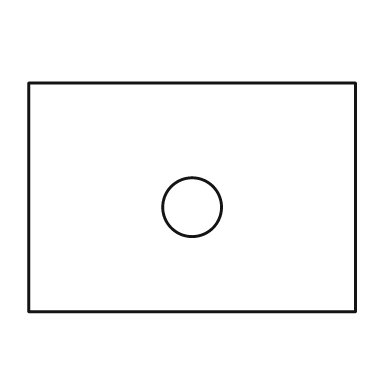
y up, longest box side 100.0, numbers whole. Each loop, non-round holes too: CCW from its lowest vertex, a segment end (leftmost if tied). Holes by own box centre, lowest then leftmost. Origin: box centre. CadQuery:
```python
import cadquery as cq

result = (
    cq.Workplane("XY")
    .moveTo(-50.0, -35.0)
    .lineTo(50.0, -35.0)
    .lineTo(50.0, 35.0)
    .lineTo(-50.0, 35.0)
    .close()
    .moveTo(0.0, -3.0)
    .circle(9.0)
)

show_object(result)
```